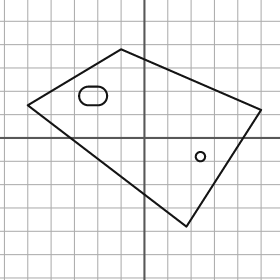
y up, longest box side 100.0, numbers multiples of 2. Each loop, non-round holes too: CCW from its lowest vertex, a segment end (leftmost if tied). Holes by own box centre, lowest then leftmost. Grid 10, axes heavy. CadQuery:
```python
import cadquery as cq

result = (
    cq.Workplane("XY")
    .moveTo(18.0, -38.0)
    .lineTo(50.0, 12.0)
    .lineTo(-10.0, 38.0)
    .lineTo(-50.0, 14.0)
    .close()
    .moveTo(24.0, -8.0)
    .circle(2.0)
    .moveTo(-24.0, 14.0)
    .lineTo(-20.0, 14.0)
    .threePointArc((-16.0, 18.0), (-20.0, 22.0))
    .lineTo(-24.0, 22.0)
    .threePointArc((-28.0, 18.0), (-24.0, 14.0))
    .close()
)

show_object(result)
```